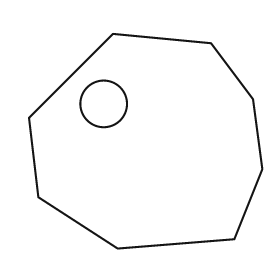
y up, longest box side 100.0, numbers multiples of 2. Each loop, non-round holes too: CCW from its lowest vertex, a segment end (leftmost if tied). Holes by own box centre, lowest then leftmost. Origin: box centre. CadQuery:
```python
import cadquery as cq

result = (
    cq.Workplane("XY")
    .moveTo(-12.0, -46.0)
    .lineTo(38.0, -42.0)
    .lineTo(50.0, -12.0)
    .lineTo(46.0, 18.0)
    .lineTo(28.0, 42.0)
    .lineTo(-14.0, 46.0)
    .lineTo(-50.0, 10.0)
    .lineTo(-46.0, -24.0)
    .close()
    .moveTo(-18.0, 16.0)
    .circle(10.0)
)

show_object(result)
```